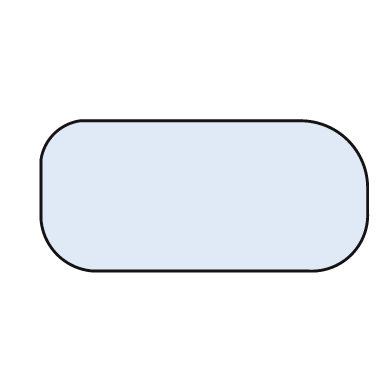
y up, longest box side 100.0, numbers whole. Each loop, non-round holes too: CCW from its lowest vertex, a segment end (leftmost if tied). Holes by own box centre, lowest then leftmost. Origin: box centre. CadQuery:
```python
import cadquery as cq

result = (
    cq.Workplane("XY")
    .moveTo(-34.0, -23.0)
    .lineTo(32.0, -23.0)
    .threePointArc((45.0, -18.0), (50.0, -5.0))
    .lineTo(50.0, 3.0)
    .threePointArc((44.0, 17.0), (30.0, 23.0))
    .lineTo(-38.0, 23.0)
    .threePointArc((-46.0, 19.0), (-50.0, 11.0))
    .lineTo(-50.0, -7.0)
    .threePointArc((-45.0, -18.0), (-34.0, -23.0))
    .close()
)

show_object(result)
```